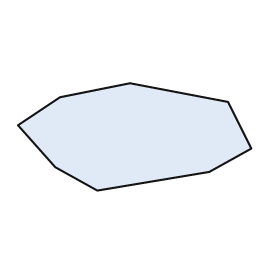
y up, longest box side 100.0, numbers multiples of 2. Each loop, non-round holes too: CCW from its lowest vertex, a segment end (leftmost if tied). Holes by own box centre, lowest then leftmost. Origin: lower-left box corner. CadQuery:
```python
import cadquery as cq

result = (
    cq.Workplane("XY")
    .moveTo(34.0, 0.0)
    .lineTo(82.0, 8.0)
    .lineTo(100.0, 18.0)
    .lineTo(90.0, 38.0)
    .lineTo(48.0, 46.0)
    .lineTo(18.0, 40.0)
    .lineTo(0.0, 28.0)
    .lineTo(16.0, 10.0)
    .close()
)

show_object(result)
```